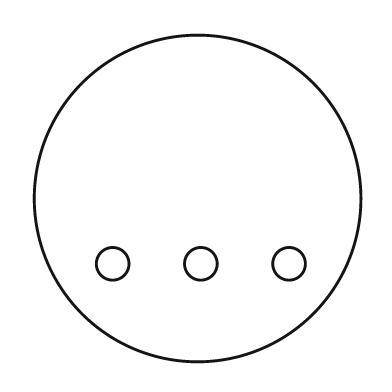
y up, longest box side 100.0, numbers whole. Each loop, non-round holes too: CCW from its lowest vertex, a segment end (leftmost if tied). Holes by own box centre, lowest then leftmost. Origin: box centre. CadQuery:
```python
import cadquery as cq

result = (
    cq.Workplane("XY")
    .moveTo(0.0, 0.0)
    .circle(50.0)
    .moveTo(-26.0, -20.0)
    .circle(5.0)
    .moveTo(1.0, -20.0)
    .circle(5.0)
    .moveTo(28.0, -20.0)
    .circle(5.0)
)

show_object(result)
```